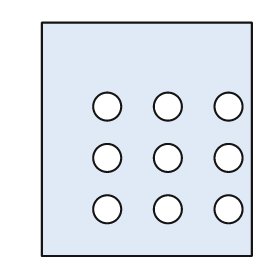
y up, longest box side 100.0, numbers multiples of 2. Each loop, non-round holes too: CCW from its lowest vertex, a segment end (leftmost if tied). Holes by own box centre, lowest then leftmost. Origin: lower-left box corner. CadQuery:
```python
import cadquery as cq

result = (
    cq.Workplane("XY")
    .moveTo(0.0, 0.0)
    .lineTo(90.0, 0.0)
    .lineTo(90.0, 100.0)
    .lineTo(0.0, 100.0)
    .close()
    .moveTo(28.0, 20.0)
    .circle(6.0)
    .moveTo(54.0, 20.0)
    .circle(6.0)
    .moveTo(80.0, 20.0)
    .circle(6.0)
    .moveTo(28.0, 42.0)
    .circle(6.0)
    .moveTo(54.0, 42.0)
    .circle(6.0)
    .moveTo(80.0, 42.0)
    .circle(6.0)
    .moveTo(28.0, 64.0)
    .circle(6.0)
    .moveTo(54.0, 64.0)
    .circle(6.0)
    .moveTo(80.0, 64.0)
    .circle(6.0)
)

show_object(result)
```